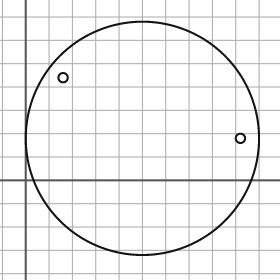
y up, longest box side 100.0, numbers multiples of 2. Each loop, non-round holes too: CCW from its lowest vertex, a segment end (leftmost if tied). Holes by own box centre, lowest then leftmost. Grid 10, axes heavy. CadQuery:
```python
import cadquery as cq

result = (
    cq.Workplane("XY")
    .moveTo(50.0, 18.0)
    .circle(50.0)
    .moveTo(92.0, 18.0)
    .circle(2.0)
    .moveTo(16.0, 44.0)
    .circle(2.0)
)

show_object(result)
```